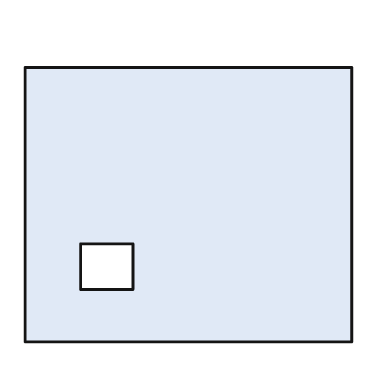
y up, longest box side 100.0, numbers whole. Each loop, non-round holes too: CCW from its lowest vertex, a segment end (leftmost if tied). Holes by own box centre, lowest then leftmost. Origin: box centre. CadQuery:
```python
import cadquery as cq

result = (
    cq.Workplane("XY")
    .moveTo(-50.0, -42.0)
    .lineTo(50.0, -42.0)
    .lineTo(50.0, 42.0)
    .lineTo(-50.0, 42.0)
    .close()
    .moveTo(-33.0, -26.0)
    .lineTo(-17.0, -26.0)
    .lineTo(-17.0, -12.0)
    .lineTo(-33.0, -12.0)
    .close()
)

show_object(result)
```